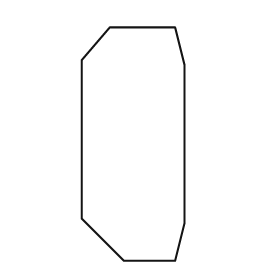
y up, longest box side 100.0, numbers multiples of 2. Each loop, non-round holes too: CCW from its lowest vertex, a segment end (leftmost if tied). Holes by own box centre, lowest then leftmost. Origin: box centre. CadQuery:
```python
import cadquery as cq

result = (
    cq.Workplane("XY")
    .moveTo(-4.0, -50.0)
    .lineTo(18.0, -50.0)
    .lineTo(22.0, -34.0)
    .lineTo(22.0, 34.0)
    .lineTo(18.0, 50.0)
    .lineTo(-10.0, 50.0)
    .lineTo(-22.0, 36.0)
    .lineTo(-22.0, -32.0)
    .close()
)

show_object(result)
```